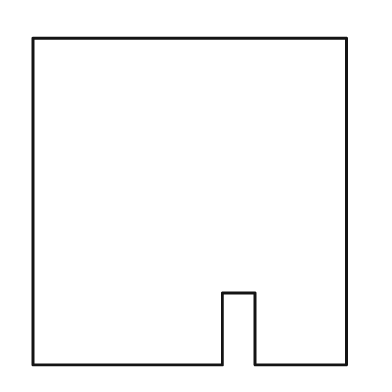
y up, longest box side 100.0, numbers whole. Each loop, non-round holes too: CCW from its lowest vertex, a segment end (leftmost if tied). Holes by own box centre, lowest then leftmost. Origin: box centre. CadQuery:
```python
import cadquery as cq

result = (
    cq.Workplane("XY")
    .moveTo(-48.0, -50.0)
    .lineTo(10.0, -50.0)
    .lineTo(10.0, -28.0)
    .lineTo(20.0, -28.0)
    .lineTo(20.0, -50.0)
    .lineTo(48.0, -50.0)
    .lineTo(48.0, 50.0)
    .lineTo(-48.0, 50.0)
    .close()
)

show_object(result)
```